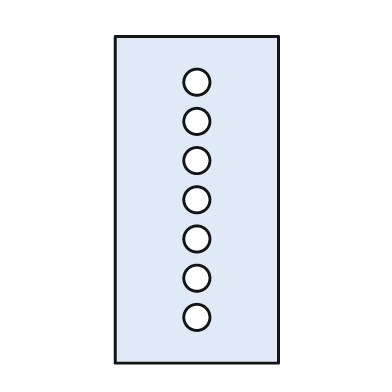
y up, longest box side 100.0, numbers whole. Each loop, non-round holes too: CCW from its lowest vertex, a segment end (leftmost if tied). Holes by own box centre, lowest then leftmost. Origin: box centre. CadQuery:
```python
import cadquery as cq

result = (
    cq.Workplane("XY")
    .moveTo(-25.0, -50.0)
    .lineTo(25.0, -50.0)
    .lineTo(25.0, 50.0)
    .lineTo(-25.0, 50.0)
    .close()
    .moveTo(0.0, -36.0)
    .circle(4.0)
    .moveTo(0.0, -24.0)
    .circle(4.0)
    .moveTo(0.0, -12.0)
    .circle(4.0)
    .moveTo(0.0, 0.0)
    .circle(4.0)
    .moveTo(0.0, 12.0)
    .circle(4.0)
    .moveTo(0.0, 24.0)
    .circle(4.0)
    .moveTo(0.0, 36.0)
    .circle(4.0)
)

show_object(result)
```